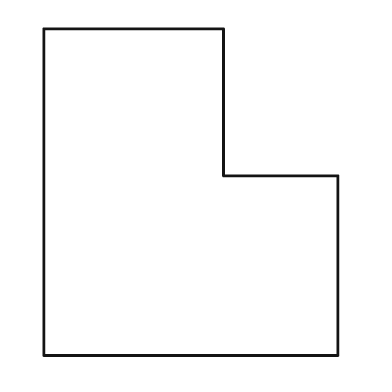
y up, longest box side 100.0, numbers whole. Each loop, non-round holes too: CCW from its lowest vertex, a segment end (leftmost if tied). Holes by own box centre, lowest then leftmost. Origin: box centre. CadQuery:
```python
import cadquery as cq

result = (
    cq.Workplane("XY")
    .moveTo(-45.0, -50.0)
    .lineTo(45.0, -50.0)
    .lineTo(45.0, 5.0)
    .lineTo(10.0, 5.0)
    .lineTo(10.0, 50.0)
    .lineTo(-45.0, 50.0)
    .close()
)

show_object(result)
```